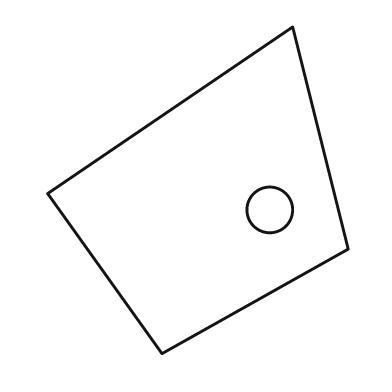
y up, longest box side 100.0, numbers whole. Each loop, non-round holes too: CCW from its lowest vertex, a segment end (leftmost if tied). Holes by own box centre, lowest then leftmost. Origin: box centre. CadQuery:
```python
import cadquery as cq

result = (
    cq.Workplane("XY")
    .moveTo(-11.0, -50.0)
    .lineTo(46.0, -18.0)
    .lineTo(29.0, 50.0)
    .lineTo(-46.0, -1.0)
    .close()
    .moveTo(22.0, -6.0)
    .circle(7.0)
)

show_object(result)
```